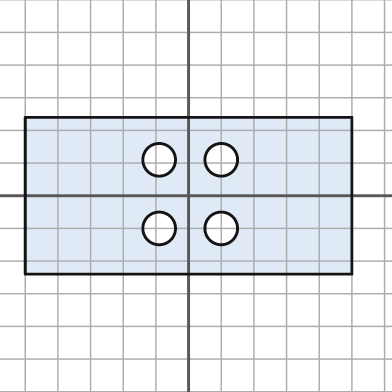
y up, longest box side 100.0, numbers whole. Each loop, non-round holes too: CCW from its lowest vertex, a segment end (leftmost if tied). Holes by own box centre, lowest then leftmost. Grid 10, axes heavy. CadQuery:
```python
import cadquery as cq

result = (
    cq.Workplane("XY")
    .moveTo(-50.0, -24.0)
    .lineTo(50.0, -24.0)
    .lineTo(50.0, 24.0)
    .lineTo(-50.0, 24.0)
    .close()
    .moveTo(-9.0, -10.0)
    .circle(5.0)
    .moveTo(10.0, -10.0)
    .circle(5.0)
    .moveTo(-9.0, 11.0)
    .circle(5.0)
    .moveTo(10.0, 11.0)
    .circle(5.0)
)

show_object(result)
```